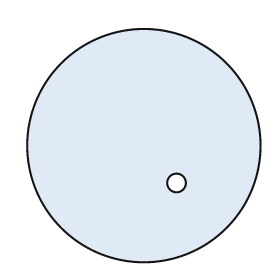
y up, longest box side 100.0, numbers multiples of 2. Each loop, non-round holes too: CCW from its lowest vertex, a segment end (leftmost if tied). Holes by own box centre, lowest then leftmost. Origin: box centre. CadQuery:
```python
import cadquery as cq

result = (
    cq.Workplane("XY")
    .moveTo(0.0, 0.0)
    .circle(50.0)
    .moveTo(14.0, -16.0)
    .circle(4.0)
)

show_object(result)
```